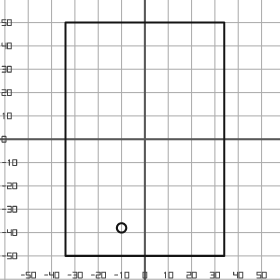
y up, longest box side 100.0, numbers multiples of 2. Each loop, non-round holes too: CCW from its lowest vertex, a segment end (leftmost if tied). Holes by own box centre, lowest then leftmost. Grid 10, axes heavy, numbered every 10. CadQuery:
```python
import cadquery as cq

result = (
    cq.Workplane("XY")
    .moveTo(-34.0, -50.0)
    .lineTo(34.0, -50.0)
    .lineTo(34.0, 50.0)
    .lineTo(-34.0, 50.0)
    .close()
    .moveTo(-10.0, -38.0)
    .circle(2.0)
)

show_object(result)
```